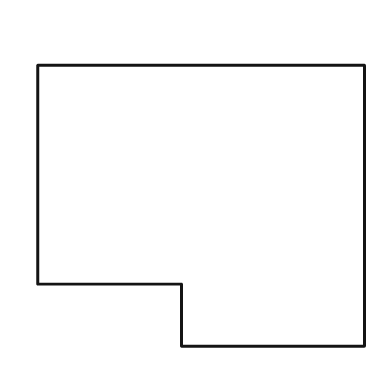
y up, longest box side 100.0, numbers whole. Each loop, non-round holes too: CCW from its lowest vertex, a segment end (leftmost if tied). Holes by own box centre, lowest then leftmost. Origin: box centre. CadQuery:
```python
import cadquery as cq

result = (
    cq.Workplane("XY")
    .moveTo(-6.0, -43.0)
    .lineTo(50.0, -43.0)
    .lineTo(50.0, 43.0)
    .lineTo(-50.0, 43.0)
    .lineTo(-50.0, -24.0)
    .lineTo(-6.0, -24.0)
    .close()
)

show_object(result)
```